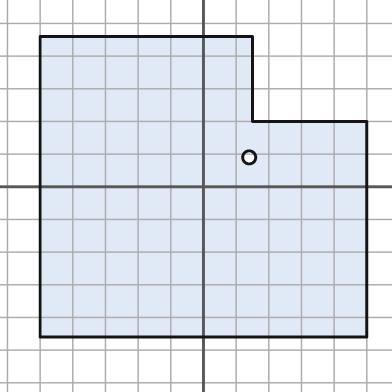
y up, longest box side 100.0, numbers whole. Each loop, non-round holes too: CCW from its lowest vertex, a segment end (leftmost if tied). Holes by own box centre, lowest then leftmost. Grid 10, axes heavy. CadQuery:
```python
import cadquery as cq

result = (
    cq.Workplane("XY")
    .moveTo(-50.0, -46.0)
    .lineTo(50.0, -46.0)
    .lineTo(50.0, 20.0)
    .lineTo(15.0, 20.0)
    .lineTo(15.0, 46.0)
    .lineTo(-50.0, 46.0)
    .close()
    .moveTo(14.0, 9.0)
    .circle(2.0)
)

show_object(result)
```